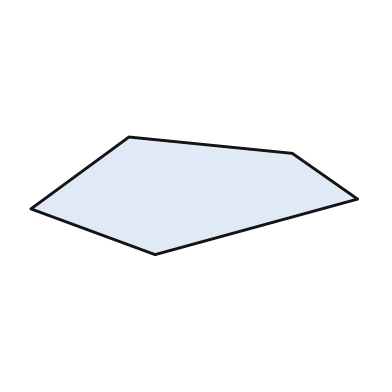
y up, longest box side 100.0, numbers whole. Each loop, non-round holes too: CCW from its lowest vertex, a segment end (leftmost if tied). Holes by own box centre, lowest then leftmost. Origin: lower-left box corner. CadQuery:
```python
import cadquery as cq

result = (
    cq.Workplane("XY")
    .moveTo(38.0, 0.0)
    .lineTo(100.0, 17.0)
    .lineTo(80.0, 31.0)
    .lineTo(30.0, 36.0)
    .lineTo(0.0, 14.0)
    .close()
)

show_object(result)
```